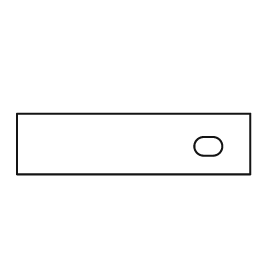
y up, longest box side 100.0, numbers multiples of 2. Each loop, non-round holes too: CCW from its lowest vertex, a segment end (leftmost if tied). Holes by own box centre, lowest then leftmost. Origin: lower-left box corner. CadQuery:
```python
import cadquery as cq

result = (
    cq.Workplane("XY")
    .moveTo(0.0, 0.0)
    .lineTo(100.0, 0.0)
    .lineTo(100.0, 26.0)
    .lineTo(0.0, 26.0)
    .close()
    .moveTo(80.0, 8.0)
    .lineTo(84.0, 8.0)
    .threePointArc((88.0, 12.0), (84.0, 16.0))
    .lineTo(80.0, 16.0)
    .threePointArc((76.0, 12.0), (80.0, 8.0))
    .close()
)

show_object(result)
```